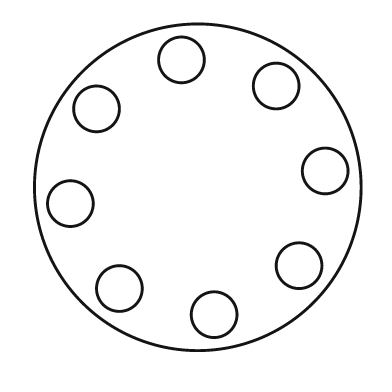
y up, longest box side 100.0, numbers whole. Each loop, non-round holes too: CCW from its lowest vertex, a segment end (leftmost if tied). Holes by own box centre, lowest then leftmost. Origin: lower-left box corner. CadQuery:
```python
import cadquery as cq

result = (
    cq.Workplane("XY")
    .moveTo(50.0, 50.0)
    .circle(50.0)
    .moveTo(55.0, 11.0)
    .circle(7.0)
    .moveTo(26.0, 19.0)
    .circle(7.0)
    .moveTo(81.0, 26.0)
    .circle(7.0)
    .moveTo(11.0, 45.0)
    .circle(7.0)
    .moveTo(89.0, 55.0)
    .circle(7.0)
    .moveTo(19.0, 74.0)
    .circle(7.0)
    .moveTo(74.0, 81.0)
    .circle(7.0)
    .moveTo(45.0, 89.0)
    .circle(7.0)
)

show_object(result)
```